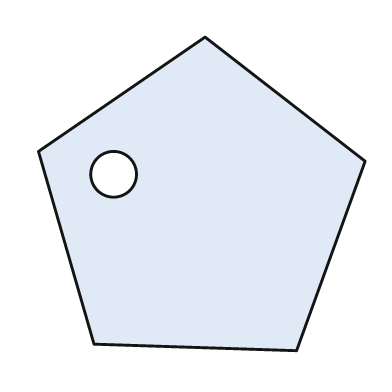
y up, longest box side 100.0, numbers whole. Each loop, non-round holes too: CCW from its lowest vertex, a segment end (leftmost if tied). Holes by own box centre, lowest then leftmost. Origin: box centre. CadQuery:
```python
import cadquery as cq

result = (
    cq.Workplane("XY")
    .moveTo(29.0, -48.0)
    .lineTo(50.0, 10.0)
    .lineTo(1.0, 48.0)
    .lineTo(-50.0, 13.0)
    .lineTo(-33.0, -46.0)
    .close()
    .moveTo(-27.0, 6.0)
    .circle(7.0)
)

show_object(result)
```